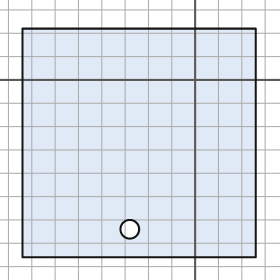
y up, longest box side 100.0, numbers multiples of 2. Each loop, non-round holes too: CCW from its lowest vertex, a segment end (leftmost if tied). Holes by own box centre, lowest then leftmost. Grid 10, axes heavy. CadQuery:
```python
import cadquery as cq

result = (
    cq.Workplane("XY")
    .moveTo(-74.0, -76.0)
    .lineTo(26.0, -76.0)
    .lineTo(26.0, 22.0)
    .lineTo(-74.0, 22.0)
    .close()
    .moveTo(-28.0, -64.0)
    .circle(4.0)
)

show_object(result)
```